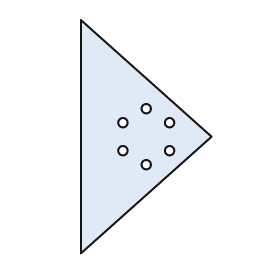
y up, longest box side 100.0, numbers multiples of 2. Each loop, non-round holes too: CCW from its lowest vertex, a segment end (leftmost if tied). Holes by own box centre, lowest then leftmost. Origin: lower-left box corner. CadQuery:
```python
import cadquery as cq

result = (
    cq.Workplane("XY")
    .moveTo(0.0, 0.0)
    .lineTo(56.0, 50.0)
    .lineTo(0.0, 100.0)
    .close()
    .moveTo(28.0, 38.0)
    .circle(2.0)
    .moveTo(18.0, 44.0)
    .circle(2.0)
    .moveTo(38.0, 44.0)
    .circle(2.0)
    .moveTo(18.0, 56.0)
    .circle(2.0)
    .moveTo(38.0, 56.0)
    .circle(2.0)
    .moveTo(28.0, 62.0)
    .circle(2.0)
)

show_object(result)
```